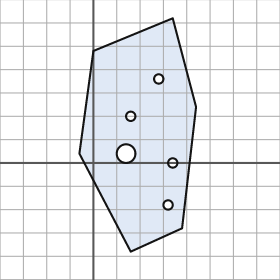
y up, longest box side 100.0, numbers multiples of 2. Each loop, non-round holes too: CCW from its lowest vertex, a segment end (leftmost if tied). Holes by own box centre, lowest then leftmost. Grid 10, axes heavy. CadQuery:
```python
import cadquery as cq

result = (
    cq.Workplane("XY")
    .moveTo(16.0, -38.0)
    .lineTo(38.0, -28.0)
    .lineTo(44.0, 24.0)
    .lineTo(34.0, 62.0)
    .lineTo(0.0, 48.0)
    .lineTo(-6.0, 4.0)
    .close()
    .moveTo(32.0, -18.0)
    .circle(2.0)
    .moveTo(34.0, 0.0)
    .circle(2.0)
    .moveTo(14.0, 4.0)
    .circle(4.0)
    .moveTo(16.0, 20.0)
    .circle(2.0)
    .moveTo(28.0, 36.0)
    .circle(2.0)
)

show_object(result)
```